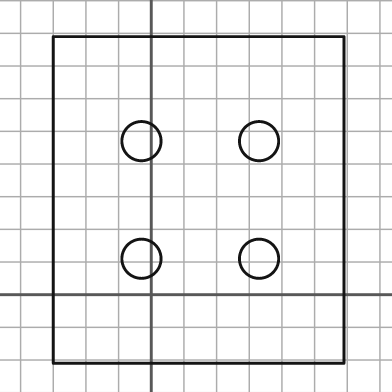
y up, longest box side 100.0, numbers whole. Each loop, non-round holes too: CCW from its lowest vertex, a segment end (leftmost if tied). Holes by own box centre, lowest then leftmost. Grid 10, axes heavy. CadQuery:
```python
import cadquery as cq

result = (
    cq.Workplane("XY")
    .moveTo(-30.0, -21.0)
    .lineTo(59.0, -21.0)
    .lineTo(59.0, 79.0)
    .lineTo(-30.0, 79.0)
    .close()
    .moveTo(-3.0, 11.0)
    .circle(6.0)
    .moveTo(33.0, 11.0)
    .circle(6.0)
    .moveTo(-3.0, 47.0)
    .circle(6.0)
    .moveTo(33.0, 47.0)
    .circle(6.0)
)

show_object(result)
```